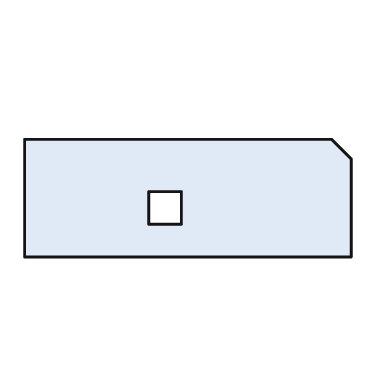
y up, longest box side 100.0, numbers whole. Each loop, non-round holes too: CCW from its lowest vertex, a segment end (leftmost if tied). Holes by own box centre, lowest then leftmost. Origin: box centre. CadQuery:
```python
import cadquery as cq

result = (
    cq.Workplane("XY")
    .moveTo(-50.0, -18.0)
    .lineTo(50.0, -18.0)
    .lineTo(50.0, 12.0)
    .lineTo(44.0, 18.0)
    .lineTo(-50.0, 18.0)
    .close()
    .moveTo(-12.0, -8.0)
    .lineTo(-2.0, -8.0)
    .lineTo(-2.0, 2.0)
    .lineTo(-12.0, 2.0)
    .close()
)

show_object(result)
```